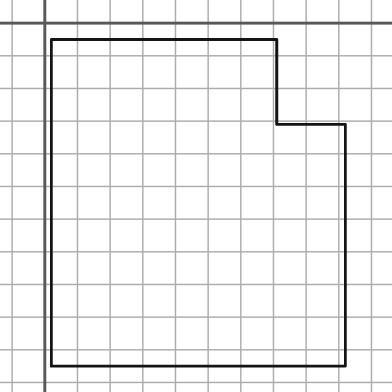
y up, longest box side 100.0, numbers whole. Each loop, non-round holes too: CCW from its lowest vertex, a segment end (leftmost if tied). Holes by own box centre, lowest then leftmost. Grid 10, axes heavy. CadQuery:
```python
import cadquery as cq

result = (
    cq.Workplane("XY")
    .moveTo(2.0, -105.0)
    .lineTo(92.0, -105.0)
    .lineTo(92.0, -31.0)
    .lineTo(71.0, -31.0)
    .lineTo(71.0, -5.0)
    .lineTo(2.0, -5.0)
    .close()
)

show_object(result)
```